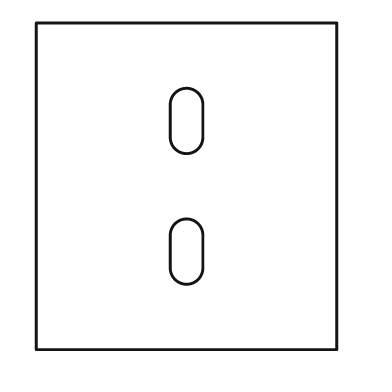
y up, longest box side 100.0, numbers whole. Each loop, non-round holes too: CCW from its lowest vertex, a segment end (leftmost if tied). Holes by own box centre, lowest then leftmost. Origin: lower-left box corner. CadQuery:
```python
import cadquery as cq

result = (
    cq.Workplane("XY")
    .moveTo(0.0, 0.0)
    .lineTo(92.0, 0.0)
    .lineTo(92.0, 100.0)
    .lineTo(0.0, 100.0)
    .close()
    .moveTo(41.0, 25.0)
    .threePointArc((46.0, 20.0), (51.0, 25.0))
    .lineTo(51.0, 35.0)
    .threePointArc((46.0, 40.0), (41.0, 35.0))
    .close()
    .moveTo(41.0, 65.0)
    .threePointArc((46.0, 60.0), (51.0, 65.0))
    .lineTo(51.0, 75.0)
    .threePointArc((46.0, 80.0), (41.0, 75.0))
    .close()
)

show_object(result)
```